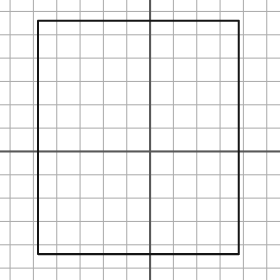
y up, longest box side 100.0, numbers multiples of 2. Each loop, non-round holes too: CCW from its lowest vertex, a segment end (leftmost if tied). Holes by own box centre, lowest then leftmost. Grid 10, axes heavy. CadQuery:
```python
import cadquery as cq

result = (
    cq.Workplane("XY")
    .moveTo(-48.0, -44.0)
    .lineTo(38.0, -44.0)
    .lineTo(38.0, 56.0)
    .lineTo(-48.0, 56.0)
    .close()
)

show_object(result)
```